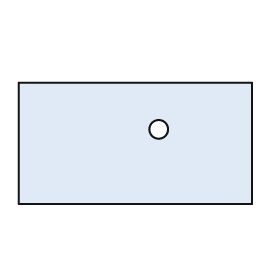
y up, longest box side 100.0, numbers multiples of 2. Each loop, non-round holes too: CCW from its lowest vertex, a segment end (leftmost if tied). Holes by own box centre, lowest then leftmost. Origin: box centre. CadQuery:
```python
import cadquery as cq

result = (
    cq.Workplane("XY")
    .moveTo(-50.0, -26.0)
    .lineTo(50.0, -26.0)
    .lineTo(50.0, 26.0)
    .lineTo(-50.0, 26.0)
    .close()
    .moveTo(10.0, 6.0)
    .circle(4.0)
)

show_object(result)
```